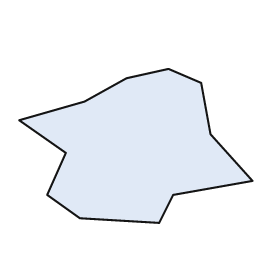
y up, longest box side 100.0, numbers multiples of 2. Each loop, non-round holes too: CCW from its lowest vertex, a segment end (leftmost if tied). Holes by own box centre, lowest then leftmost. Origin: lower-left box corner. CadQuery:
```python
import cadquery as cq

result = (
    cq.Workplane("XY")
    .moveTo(60.0, 0.0)
    .lineTo(66.0, 12.0)
    .lineTo(100.0, 18.0)
    .lineTo(82.0, 38.0)
    .lineTo(78.0, 60.0)
    .lineTo(64.0, 66.0)
    .lineTo(46.0, 62.0)
    .lineTo(28.0, 52.0)
    .lineTo(0.0, 44.0)
    .lineTo(20.0, 30.0)
    .lineTo(12.0, 12.0)
    .lineTo(26.0, 2.0)
    .close()
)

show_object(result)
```